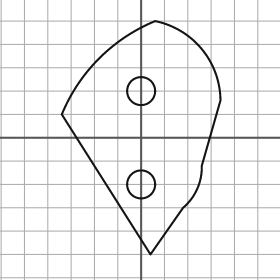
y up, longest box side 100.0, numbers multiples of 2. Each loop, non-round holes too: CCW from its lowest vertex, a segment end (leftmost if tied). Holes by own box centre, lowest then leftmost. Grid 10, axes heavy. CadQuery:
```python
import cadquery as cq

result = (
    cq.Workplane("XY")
    .moveTo(4.0, -50.0)
    .lineTo(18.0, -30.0)
    .threePointArc((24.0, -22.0), (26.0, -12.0))
    .lineTo(34.0, 16.0)
    .threePointArc((26.0, 38.0), (6.0, 50.0))
    .threePointArc((-18.0, 34.0), (-34.0, 10.0))
    .close()
    .moveTo(0.0, -20.0)
    .circle(6.0)
    .moveTo(0.0, 20.0)
    .circle(6.0)
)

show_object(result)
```